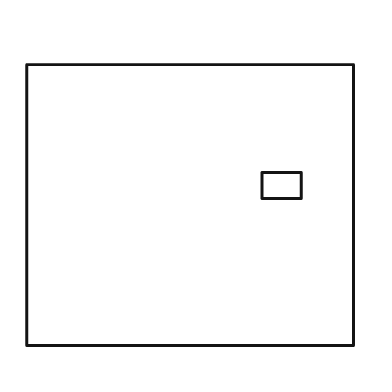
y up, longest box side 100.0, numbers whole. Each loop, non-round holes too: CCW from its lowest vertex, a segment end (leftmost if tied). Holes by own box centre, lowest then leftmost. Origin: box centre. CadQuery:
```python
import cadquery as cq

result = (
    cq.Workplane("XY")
    .moveTo(-50.0, -43.0)
    .lineTo(50.0, -43.0)
    .lineTo(50.0, 43.0)
    .lineTo(-50.0, 43.0)
    .close()
    .moveTo(22.0, 2.0)
    .lineTo(34.0, 2.0)
    .lineTo(34.0, 10.0)
    .lineTo(22.0, 10.0)
    .close()
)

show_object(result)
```